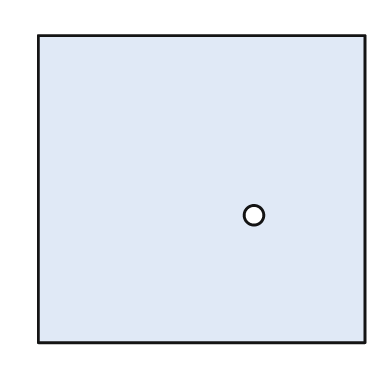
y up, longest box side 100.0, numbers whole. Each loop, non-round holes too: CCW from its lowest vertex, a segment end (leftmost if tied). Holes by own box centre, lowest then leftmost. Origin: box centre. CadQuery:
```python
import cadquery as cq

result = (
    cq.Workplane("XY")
    .moveTo(-50.0, -47.0)
    .lineTo(50.0, -47.0)
    .lineTo(50.0, 47.0)
    .lineTo(-50.0, 47.0)
    .close()
    .moveTo(16.0, -8.0)
    .circle(3.0)
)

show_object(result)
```